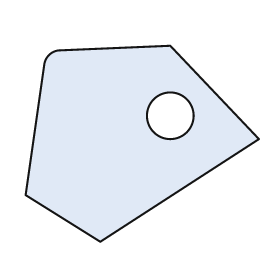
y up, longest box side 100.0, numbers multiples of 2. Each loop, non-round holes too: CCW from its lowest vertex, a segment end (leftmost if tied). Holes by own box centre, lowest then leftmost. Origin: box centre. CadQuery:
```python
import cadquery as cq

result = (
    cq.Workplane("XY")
    .moveTo(-18.0, -42.0)
    .lineTo(50.0, 2.0)
    .lineTo(12.0, 42.0)
    .lineTo(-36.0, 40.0)
    .threePointArc((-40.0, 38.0), (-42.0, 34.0))
    .lineTo(-50.0, -22.0)
    .close()
    .moveTo(12.0, 12.0)
    .circle(10.0)
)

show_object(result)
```